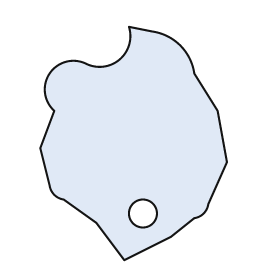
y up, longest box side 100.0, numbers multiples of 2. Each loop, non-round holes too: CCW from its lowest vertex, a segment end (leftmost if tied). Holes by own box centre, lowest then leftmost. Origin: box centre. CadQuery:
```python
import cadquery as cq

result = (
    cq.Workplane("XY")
    .moveTo(-4.0, -50.0)
    .lineTo(16.0, -40.0)
    .lineTo(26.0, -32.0)
    .threePointArc((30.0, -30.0), (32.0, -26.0))
    .lineTo(40.0, -8.0)
    .lineTo(36.0, 14.0)
    .lineTo(26.0, 30.0)
    .threePointArc((20.0, 42.0), (8.0, 48.0))
    .lineTo(-2.0, 50.0)
    .threePointArc((-6.0, 36.0), (-20.0, 34.0))
    .threePointArc((-36.0, 30.0), (-34.0, 14.0))
    .lineTo(-40.0, -2.0)
    .lineTo(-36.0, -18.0)
    .threePointArc((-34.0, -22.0), (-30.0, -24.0))
    .lineTo(-16.0, -34.0)
    .close()
    .moveTo(4.0, -30.0)
    .circle(6.0)
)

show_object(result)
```